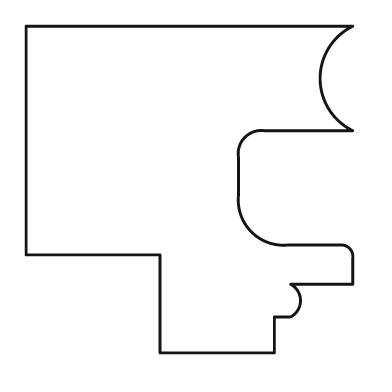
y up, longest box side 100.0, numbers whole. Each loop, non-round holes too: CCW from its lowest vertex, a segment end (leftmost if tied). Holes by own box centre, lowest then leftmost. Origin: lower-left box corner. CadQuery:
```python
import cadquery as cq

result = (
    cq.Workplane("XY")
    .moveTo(41.0, 0.0)
    .lineTo(76.0, 0.0)
    .lineTo(76.0, 11.0)
    .lineTo(81.0, 11.0)
    .threePointArc((84.0, 16.0), (81.0, 21.0))
    .lineTo(100.0, 21.0)
    .lineTo(100.0, 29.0)
    .threePointArc((99.0, 32.0), (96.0, 33.0))
    .lineTo(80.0, 33.0)
    .threePointArc((69.0, 37.0), (65.0, 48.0))
    .lineTo(65.0, 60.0)
    .threePointArc((67.0, 66.0), (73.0, 68.0))
    .lineTo(100.0, 68.0)
    .threePointArc((90.0, 84.0), (100.0, 100.0))
    .lineTo(0.0, 100.0)
    .lineTo(0.0, 30.0)
    .lineTo(41.0, 30.0)
    .close()
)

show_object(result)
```